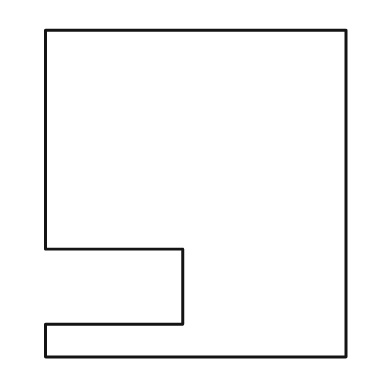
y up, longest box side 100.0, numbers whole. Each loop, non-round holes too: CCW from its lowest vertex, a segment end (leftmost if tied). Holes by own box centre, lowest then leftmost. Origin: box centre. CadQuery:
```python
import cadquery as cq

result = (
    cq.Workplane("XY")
    .moveTo(-46.0, -50.0)
    .lineTo(46.0, -50.0)
    .lineTo(46.0, 50.0)
    .lineTo(-46.0, 50.0)
    .lineTo(-46.0, -17.0)
    .lineTo(-4.0, -17.0)
    .lineTo(-4.0, -40.0)
    .lineTo(-46.0, -40.0)
    .close()
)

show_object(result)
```